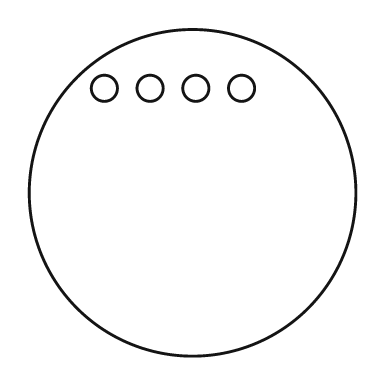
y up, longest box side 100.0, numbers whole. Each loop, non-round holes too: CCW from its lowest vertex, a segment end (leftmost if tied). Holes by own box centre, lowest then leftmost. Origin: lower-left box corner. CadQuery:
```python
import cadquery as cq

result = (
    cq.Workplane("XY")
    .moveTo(50.0, 50.0)
    .circle(50.0)
    .moveTo(23.0, 82.0)
    .circle(4.0)
    .moveTo(37.0, 82.0)
    .circle(4.0)
    .moveTo(51.0, 82.0)
    .circle(4.0)
    .moveTo(65.0, 82.0)
    .circle(4.0)
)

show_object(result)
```